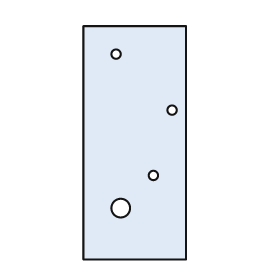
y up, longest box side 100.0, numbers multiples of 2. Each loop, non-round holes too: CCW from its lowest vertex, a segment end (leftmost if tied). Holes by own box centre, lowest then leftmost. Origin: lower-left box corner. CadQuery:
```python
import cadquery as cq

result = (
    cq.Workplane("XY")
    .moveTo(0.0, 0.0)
    .lineTo(44.0, 0.0)
    .lineTo(44.0, 100.0)
    .lineTo(0.0, 100.0)
    .close()
    .moveTo(16.0, 22.0)
    .circle(4.0)
    .moveTo(30.0, 36.0)
    .circle(2.0)
    .moveTo(38.0, 64.0)
    .circle(2.0)
    .moveTo(14.0, 88.0)
    .circle(2.0)
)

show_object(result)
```